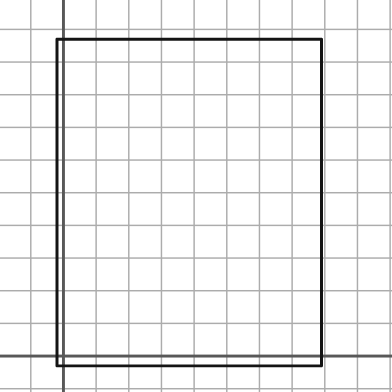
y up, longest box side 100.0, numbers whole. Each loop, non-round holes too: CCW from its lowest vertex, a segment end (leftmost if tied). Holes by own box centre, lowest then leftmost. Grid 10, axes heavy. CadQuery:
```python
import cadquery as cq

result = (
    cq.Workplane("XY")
    .moveTo(-2.0, -3.0)
    .lineTo(79.0, -3.0)
    .lineTo(79.0, 97.0)
    .lineTo(-2.0, 97.0)
    .close()
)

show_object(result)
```